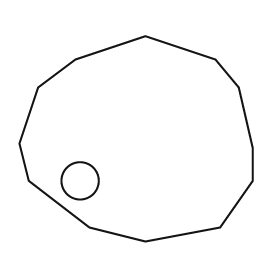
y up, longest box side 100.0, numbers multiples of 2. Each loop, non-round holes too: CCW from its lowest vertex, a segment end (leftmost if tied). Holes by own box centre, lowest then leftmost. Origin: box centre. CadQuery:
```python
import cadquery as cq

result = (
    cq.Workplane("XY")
    .moveTo(4.0, -44.0)
    .lineTo(36.0, -38.0)
    .lineTo(50.0, -18.0)
    .lineTo(50.0, -4.0)
    .lineTo(44.0, 22.0)
    .lineTo(34.0, 34.0)
    .lineTo(4.0, 44.0)
    .lineTo(-26.0, 34.0)
    .lineTo(-42.0, 22.0)
    .lineTo(-50.0, -2.0)
    .lineTo(-46.0, -18.0)
    .lineTo(-20.0, -38.0)
    .close()
    .moveTo(-24.0, -18.0)
    .circle(8.0)
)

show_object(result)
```